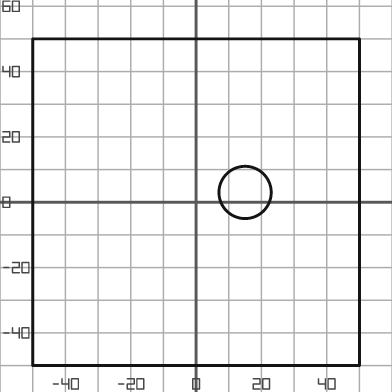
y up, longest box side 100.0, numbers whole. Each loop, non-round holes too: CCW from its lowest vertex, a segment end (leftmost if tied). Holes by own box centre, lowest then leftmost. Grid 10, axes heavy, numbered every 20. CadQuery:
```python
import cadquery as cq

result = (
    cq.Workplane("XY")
    .moveTo(-50.0, -50.0)
    .lineTo(50.0, -50.0)
    .lineTo(50.0, 50.0)
    .lineTo(-50.0, 50.0)
    .close()
    .moveTo(15.0, 3.0)
    .circle(8.0)
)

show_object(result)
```